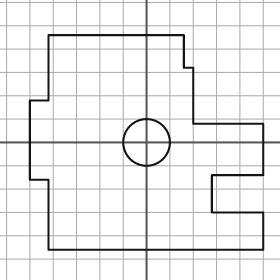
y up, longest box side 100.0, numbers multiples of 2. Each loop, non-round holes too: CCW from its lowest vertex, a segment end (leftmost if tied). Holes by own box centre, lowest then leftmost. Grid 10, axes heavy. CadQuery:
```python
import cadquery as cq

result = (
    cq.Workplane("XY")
    .moveTo(-42.0, -46.0)
    .lineTo(50.0, -46.0)
    .lineTo(50.0, -30.0)
    .lineTo(28.0, -30.0)
    .lineTo(28.0, -14.0)
    .lineTo(50.0, -14.0)
    .lineTo(50.0, 8.0)
    .lineTo(20.0, 8.0)
    .lineTo(20.0, 32.0)
    .lineTo(16.0, 32.0)
    .lineTo(16.0, 46.0)
    .lineTo(-42.0, 46.0)
    .lineTo(-42.0, 18.0)
    .lineTo(-50.0, 18.0)
    .lineTo(-50.0, -16.0)
    .lineTo(-42.0, -16.0)
    .close()
    .moveTo(0.0, 0.0)
    .circle(10.0)
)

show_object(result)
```